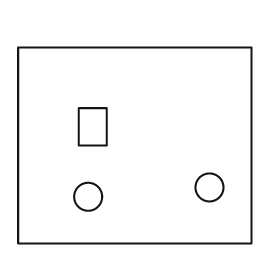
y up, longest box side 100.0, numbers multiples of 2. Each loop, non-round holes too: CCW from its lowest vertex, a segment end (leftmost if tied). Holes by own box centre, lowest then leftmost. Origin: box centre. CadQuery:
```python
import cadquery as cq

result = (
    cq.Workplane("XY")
    .moveTo(-50.0, -42.0)
    .lineTo(50.0, -42.0)
    .lineTo(50.0, 42.0)
    .lineTo(-50.0, 42.0)
    .close()
    .moveTo(-20.0, -22.0)
    .circle(6.0)
    .moveTo(32.0, -18.0)
    .circle(6.0)
    .moveTo(-24.0, 0.0)
    .lineTo(-12.0, 0.0)
    .lineTo(-12.0, 16.0)
    .lineTo(-24.0, 16.0)
    .close()
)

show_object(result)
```